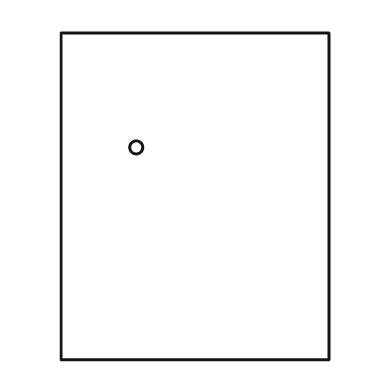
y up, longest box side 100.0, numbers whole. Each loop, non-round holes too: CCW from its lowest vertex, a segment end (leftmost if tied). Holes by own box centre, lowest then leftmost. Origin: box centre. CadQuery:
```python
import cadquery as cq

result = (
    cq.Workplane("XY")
    .moveTo(-41.0, -50.0)
    .lineTo(41.0, -50.0)
    .lineTo(41.0, 50.0)
    .lineTo(-41.0, 50.0)
    .close()
    .moveTo(-18.0, 15.0)
    .circle(2.0)
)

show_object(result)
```